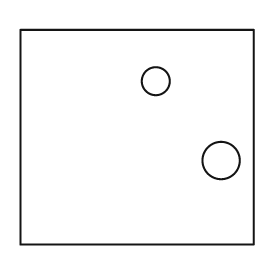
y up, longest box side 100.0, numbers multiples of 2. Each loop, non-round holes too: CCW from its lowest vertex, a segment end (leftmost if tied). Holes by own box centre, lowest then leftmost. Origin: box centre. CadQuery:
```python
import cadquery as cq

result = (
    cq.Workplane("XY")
    .moveTo(-50.0, -46.0)
    .lineTo(50.0, -46.0)
    .lineTo(50.0, 46.0)
    .lineTo(-50.0, 46.0)
    .close()
    .moveTo(36.0, -10.0)
    .circle(8.0)
    .moveTo(8.0, 24.0)
    .circle(6.0)
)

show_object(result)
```